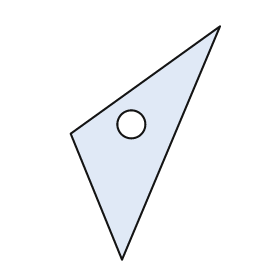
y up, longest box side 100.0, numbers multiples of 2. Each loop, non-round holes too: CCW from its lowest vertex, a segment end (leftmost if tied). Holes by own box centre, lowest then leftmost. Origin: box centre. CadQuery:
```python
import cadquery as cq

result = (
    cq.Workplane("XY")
    .moveTo(-10.0, -50.0)
    .lineTo(32.0, 50.0)
    .lineTo(-32.0, 4.0)
    .close()
    .moveTo(-6.0, 8.0)
    .circle(6.0)
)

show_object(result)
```